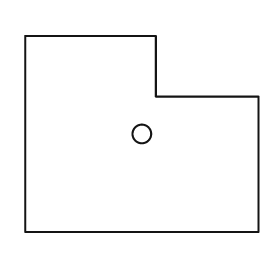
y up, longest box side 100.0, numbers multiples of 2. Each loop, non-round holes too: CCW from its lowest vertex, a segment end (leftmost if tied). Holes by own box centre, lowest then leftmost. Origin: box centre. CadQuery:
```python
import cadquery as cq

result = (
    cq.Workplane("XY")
    .moveTo(-50.0, -42.0)
    .lineTo(50.0, -42.0)
    .lineTo(50.0, 16.0)
    .lineTo(6.0, 16.0)
    .lineTo(6.0, 42.0)
    .lineTo(-50.0, 42.0)
    .close()
    .moveTo(0.0, 0.0)
    .circle(4.0)
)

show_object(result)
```